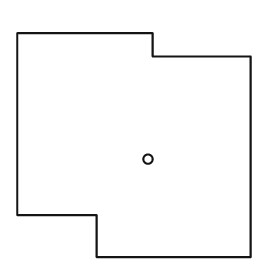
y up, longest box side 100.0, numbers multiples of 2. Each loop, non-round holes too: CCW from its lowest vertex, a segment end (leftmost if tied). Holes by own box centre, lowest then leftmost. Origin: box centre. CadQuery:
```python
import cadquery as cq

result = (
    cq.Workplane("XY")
    .moveTo(-16.0, -48.0)
    .lineTo(50.0, -48.0)
    .lineTo(50.0, 38.0)
    .lineTo(8.0, 38.0)
    .lineTo(8.0, 48.0)
    .lineTo(-50.0, 48.0)
    .lineTo(-50.0, -30.0)
    .lineTo(-16.0, -30.0)
    .close()
    .moveTo(6.0, -6.0)
    .circle(2.0)
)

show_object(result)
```